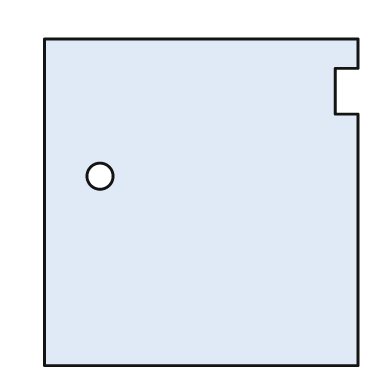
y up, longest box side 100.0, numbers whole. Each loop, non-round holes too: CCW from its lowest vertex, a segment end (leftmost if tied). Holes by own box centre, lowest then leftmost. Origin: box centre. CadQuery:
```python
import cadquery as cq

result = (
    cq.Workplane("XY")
    .moveTo(-48.0, -50.0)
    .lineTo(48.0, -50.0)
    .lineTo(48.0, 27.0)
    .lineTo(41.0, 27.0)
    .lineTo(41.0, 41.0)
    .lineTo(48.0, 41.0)
    .lineTo(48.0, 50.0)
    .lineTo(-48.0, 50.0)
    .close()
    .moveTo(-31.0, 8.0)
    .circle(4.0)
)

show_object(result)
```